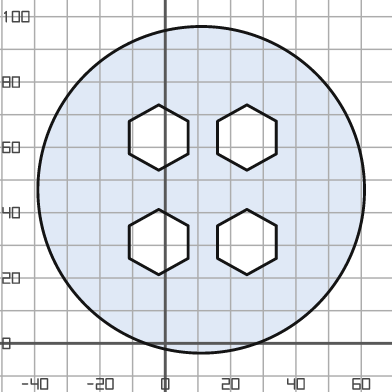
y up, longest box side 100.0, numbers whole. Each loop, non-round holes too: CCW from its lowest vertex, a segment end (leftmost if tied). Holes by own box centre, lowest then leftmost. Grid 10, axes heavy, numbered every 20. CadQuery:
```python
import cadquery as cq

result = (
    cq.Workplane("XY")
    .moveTo(11.0, 47.0)
    .circle(50.0)
    .moveTo(-2.0, 21.0)
    .lineTo(7.0, 26.0)
    .lineTo(7.0, 36.0)
    .lineTo(-2.0, 41.0)
    .lineTo(-11.0, 36.0)
    .lineTo(-11.0, 26.0)
    .close()
    .moveTo(25.0, 21.0)
    .lineTo(34.0, 26.0)
    .lineTo(34.0, 36.0)
    .lineTo(25.0, 41.0)
    .lineTo(16.0, 36.0)
    .lineTo(16.0, 26.0)
    .close()
    .moveTo(-2.0, 53.0)
    .lineTo(7.0, 58.0)
    .lineTo(7.0, 68.0)
    .lineTo(-2.0, 73.0)
    .lineTo(-11.0, 68.0)
    .lineTo(-11.0, 58.0)
    .close()
    .moveTo(25.0, 53.0)
    .lineTo(34.0, 58.0)
    .lineTo(34.0, 68.0)
    .lineTo(25.0, 73.0)
    .lineTo(16.0, 68.0)
    .lineTo(16.0, 58.0)
    .close()
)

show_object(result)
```